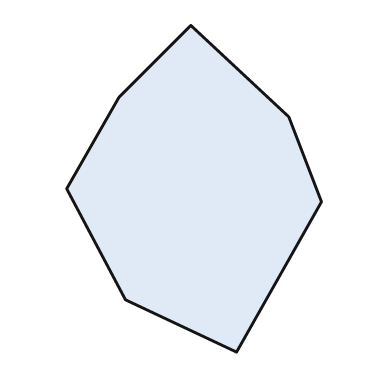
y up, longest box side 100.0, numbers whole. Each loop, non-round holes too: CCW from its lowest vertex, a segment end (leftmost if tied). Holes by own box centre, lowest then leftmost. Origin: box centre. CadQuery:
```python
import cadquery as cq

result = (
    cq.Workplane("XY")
    .moveTo(13.0, -50.0)
    .lineTo(39.0, -4.0)
    .lineTo(29.0, 22.0)
    .lineTo(-1.0, 50.0)
    .lineTo(-23.0, 28.0)
    .lineTo(-39.0, 0.0)
    .lineTo(-21.0, -34.0)
    .close()
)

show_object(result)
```